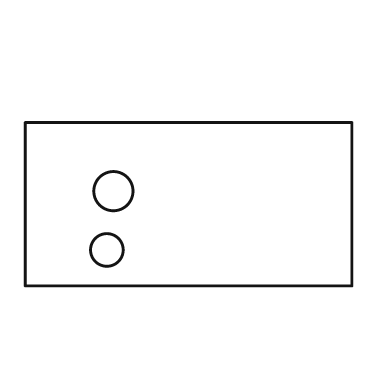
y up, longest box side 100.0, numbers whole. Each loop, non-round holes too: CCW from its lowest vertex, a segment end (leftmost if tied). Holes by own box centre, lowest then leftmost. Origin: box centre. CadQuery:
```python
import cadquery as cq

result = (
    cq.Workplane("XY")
    .moveTo(-50.0, -25.0)
    .lineTo(50.0, -25.0)
    .lineTo(50.0, 25.0)
    .lineTo(-50.0, 25.0)
    .close()
    .moveTo(-25.0, -14.0)
    .circle(5.0)
    .moveTo(-23.0, 4.0)
    .circle(6.0)
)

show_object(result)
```